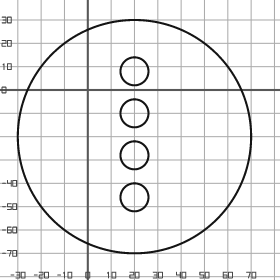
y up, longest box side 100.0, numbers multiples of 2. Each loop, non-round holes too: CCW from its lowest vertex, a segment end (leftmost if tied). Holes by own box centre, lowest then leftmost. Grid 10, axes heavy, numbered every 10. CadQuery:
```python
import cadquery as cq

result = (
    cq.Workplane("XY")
    .moveTo(20.0, -20.0)
    .circle(50.0)
    .moveTo(20.0, -46.0)
    .circle(6.0)
    .moveTo(20.0, -28.0)
    .circle(6.0)
    .moveTo(20.0, -10.0)
    .circle(6.0)
    .moveTo(20.0, 8.0)
    .circle(6.0)
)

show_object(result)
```